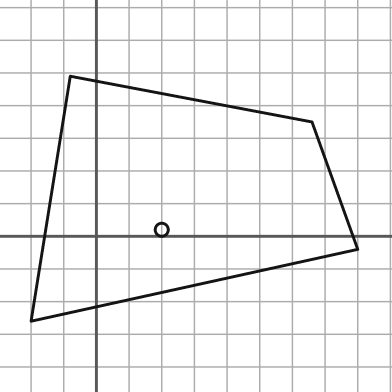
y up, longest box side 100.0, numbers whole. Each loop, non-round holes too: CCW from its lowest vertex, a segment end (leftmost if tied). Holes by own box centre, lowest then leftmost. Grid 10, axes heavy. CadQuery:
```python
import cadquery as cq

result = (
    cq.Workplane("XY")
    .moveTo(-20.0, -26.0)
    .lineTo(80.0, -4.0)
    .lineTo(66.0, 35.0)
    .lineTo(-8.0, 49.0)
    .close()
    .moveTo(20.0, 2.0)
    .circle(2.0)
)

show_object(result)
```